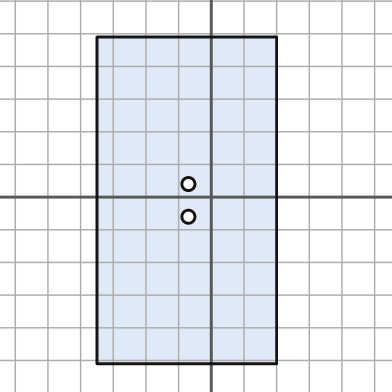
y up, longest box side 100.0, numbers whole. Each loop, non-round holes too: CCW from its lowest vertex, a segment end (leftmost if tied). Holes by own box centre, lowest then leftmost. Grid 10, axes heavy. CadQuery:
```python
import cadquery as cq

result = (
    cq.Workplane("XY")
    .moveTo(-35.0, -51.0)
    .lineTo(20.0, -51.0)
    .lineTo(20.0, 49.0)
    .lineTo(-35.0, 49.0)
    .close()
    .moveTo(-7.0, -6.0)
    .circle(2.0)
    .moveTo(-7.0, 4.0)
    .circle(2.0)
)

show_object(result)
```